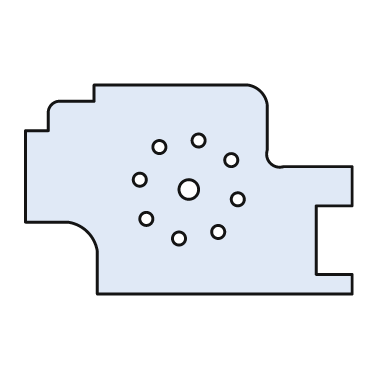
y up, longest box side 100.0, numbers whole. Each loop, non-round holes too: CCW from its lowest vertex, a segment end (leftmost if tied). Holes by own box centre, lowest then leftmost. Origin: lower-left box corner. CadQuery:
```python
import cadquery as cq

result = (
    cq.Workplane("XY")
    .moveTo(22.0, 0.0)
    .lineTo(100.0, 0.0)
    .lineTo(100.0, 6.0)
    .lineTo(89.0, 6.0)
    .lineTo(89.0, 27.0)
    .lineTo(100.0, 27.0)
    .lineTo(100.0, 39.0)
    .lineTo(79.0, 39.0)
    .threePointArc((75.0, 40.0), (74.0, 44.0))
    .lineTo(74.0, 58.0)
    .threePointArc((72.0, 62.0), (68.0, 64.0))
    .lineTo(21.0, 64.0)
    .lineTo(21.0, 59.0)
    .lineTo(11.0, 59.0)
    .threePointArc((8.0, 58.0), (7.0, 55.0))
    .lineTo(7.0, 50.0)
    .lineTo(0.0, 50.0)
    .lineTo(0.0, 22.0)
    .lineTo(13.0, 22.0)
    .threePointArc((19.0, 19.0), (22.0, 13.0))
    .close()
    .moveTo(47.0, 17.0)
    .circle(2.0)
    .moveTo(59.0, 19.0)
    .circle(2.0)
    .moveTo(37.0, 23.0)
    .circle(2.0)
    .moveTo(65.0, 29.0)
    .circle(2.0)
    .moveTo(50.0, 32.0)
    .circle(3.0)
    .moveTo(35.0, 35.0)
    .circle(2.0)
    .moveTo(63.0, 41.0)
    .circle(2.0)
    .moveTo(41.0, 45.0)
    .circle(2.0)
    .moveTo(53.0, 47.0)
    .circle(2.0)
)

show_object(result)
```